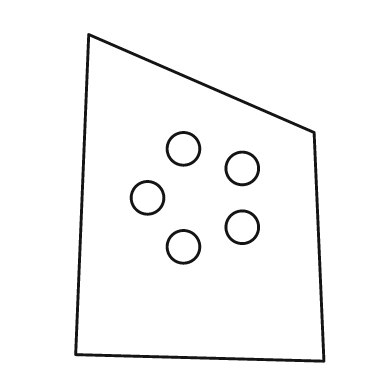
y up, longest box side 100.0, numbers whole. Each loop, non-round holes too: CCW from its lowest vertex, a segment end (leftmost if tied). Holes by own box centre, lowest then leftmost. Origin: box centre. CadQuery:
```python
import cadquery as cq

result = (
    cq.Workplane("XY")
    .moveTo(38.0, -50.0)
    .lineTo(35.0, 20.0)
    .lineTo(-34.0, 50.0)
    .lineTo(-38.0, -48.0)
    .close()
    .moveTo(-5.0, -15.0)
    .circle(5.0)
    .moveTo(13.0, -9.0)
    .circle(5.0)
    .moveTo(-16.0, 0.0)
    .circle(5.0)
    .moveTo(13.0, 9.0)
    .circle(5.0)
    .moveTo(-5.0, 15.0)
    .circle(5.0)
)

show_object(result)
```